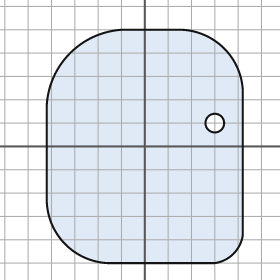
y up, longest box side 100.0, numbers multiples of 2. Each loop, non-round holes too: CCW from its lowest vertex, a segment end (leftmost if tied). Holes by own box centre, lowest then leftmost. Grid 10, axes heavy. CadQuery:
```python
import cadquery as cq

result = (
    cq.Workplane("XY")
    .moveTo(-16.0, -50.0)
    .lineTo(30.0, -50.0)
    .threePointArc((38.0, -46.0), (42.0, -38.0))
    .lineTo(42.0, 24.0)
    .threePointArc((34.0, 42.0), (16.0, 50.0))
    .lineTo(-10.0, 50.0)
    .threePointArc((-32.0, 40.0), (-42.0, 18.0))
    .lineTo(-42.0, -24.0)
    .threePointArc((-34.0, -42.0), (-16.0, -50.0))
    .close()
    .moveTo(30.0, 10.0)
    .circle(4.0)
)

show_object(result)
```